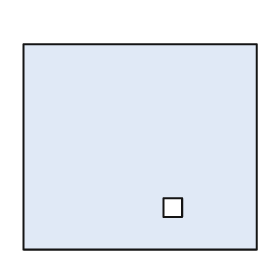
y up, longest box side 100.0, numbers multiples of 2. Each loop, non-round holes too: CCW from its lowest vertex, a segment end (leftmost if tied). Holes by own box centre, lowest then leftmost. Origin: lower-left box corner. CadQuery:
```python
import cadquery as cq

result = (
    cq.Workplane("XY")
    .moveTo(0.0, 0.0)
    .lineTo(100.0, 0.0)
    .lineTo(100.0, 88.0)
    .lineTo(0.0, 88.0)
    .close()
    .moveTo(60.0, 14.0)
    .lineTo(68.0, 14.0)
    .lineTo(68.0, 22.0)
    .lineTo(60.0, 22.0)
    .close()
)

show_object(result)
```